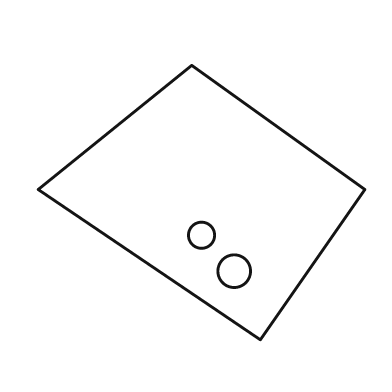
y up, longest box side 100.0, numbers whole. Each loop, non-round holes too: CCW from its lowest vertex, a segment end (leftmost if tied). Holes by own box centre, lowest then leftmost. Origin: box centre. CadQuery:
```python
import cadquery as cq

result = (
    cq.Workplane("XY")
    .moveTo(18.0, -42.0)
    .lineTo(50.0, 4.0)
    .lineTo(-3.0, 42.0)
    .lineTo(-50.0, 4.0)
    .close()
    .moveTo(10.0, -21.0)
    .circle(5.0)
    .moveTo(0.0, -10.0)
    .circle(4.0)
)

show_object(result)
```